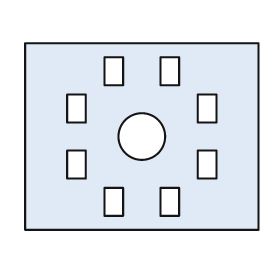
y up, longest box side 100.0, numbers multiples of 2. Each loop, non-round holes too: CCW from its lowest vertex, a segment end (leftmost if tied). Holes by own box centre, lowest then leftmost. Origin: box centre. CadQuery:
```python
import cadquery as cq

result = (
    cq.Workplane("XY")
    .moveTo(-50.0, -40.0)
    .lineTo(50.0, -40.0)
    .lineTo(50.0, 40.0)
    .lineTo(-50.0, 40.0)
    .close()
    .moveTo(-16.0, -34.0)
    .lineTo(-8.0, -34.0)
    .lineTo(-8.0, -22.0)
    .lineTo(-16.0, -22.0)
    .close()
    .moveTo(8.0, -34.0)
    .lineTo(16.0, -34.0)
    .lineTo(16.0, -22.0)
    .lineTo(8.0, -22.0)
    .close()
    .moveTo(-32.0, -18.0)
    .lineTo(-24.0, -18.0)
    .lineTo(-24.0, -6.0)
    .lineTo(-32.0, -6.0)
    .close()
    .moveTo(24.0, -18.0)
    .lineTo(32.0, -18.0)
    .lineTo(32.0, -6.0)
    .lineTo(24.0, -6.0)
    .close()
    .moveTo(0.0, 0.0)
    .circle(10.0)
    .moveTo(-32.0, 6.0)
    .lineTo(-24.0, 6.0)
    .lineTo(-24.0, 18.0)
    .lineTo(-32.0, 18.0)
    .close()
    .moveTo(24.0, 6.0)
    .lineTo(32.0, 6.0)
    .lineTo(32.0, 18.0)
    .lineTo(24.0, 18.0)
    .close()
    .moveTo(-16.0, 22.0)
    .lineTo(-8.0, 22.0)
    .lineTo(-8.0, 34.0)
    .lineTo(-16.0, 34.0)
    .close()
    .moveTo(8.0, 22.0)
    .lineTo(16.0, 22.0)
    .lineTo(16.0, 34.0)
    .lineTo(8.0, 34.0)
    .close()
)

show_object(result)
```